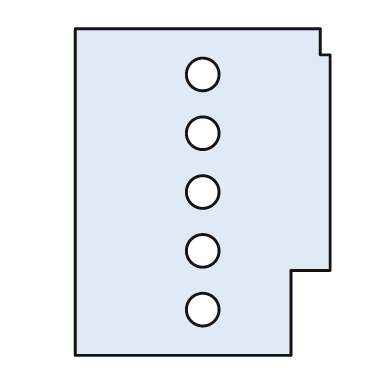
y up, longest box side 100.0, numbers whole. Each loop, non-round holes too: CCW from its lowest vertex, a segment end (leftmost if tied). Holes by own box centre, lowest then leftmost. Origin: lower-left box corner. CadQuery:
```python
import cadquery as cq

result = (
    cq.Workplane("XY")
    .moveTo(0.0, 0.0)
    .lineTo(66.0, 0.0)
    .lineTo(66.0, 26.0)
    .lineTo(78.0, 26.0)
    .lineTo(78.0, 92.0)
    .lineTo(75.0, 92.0)
    .lineTo(75.0, 100.0)
    .lineTo(0.0, 100.0)
    .close()
    .moveTo(39.0, 14.0)
    .circle(5.0)
    .moveTo(39.0, 32.0)
    .circle(5.0)
    .moveTo(39.0, 50.0)
    .circle(5.0)
    .moveTo(39.0, 68.0)
    .circle(5.0)
    .moveTo(39.0, 86.0)
    .circle(5.0)
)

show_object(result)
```